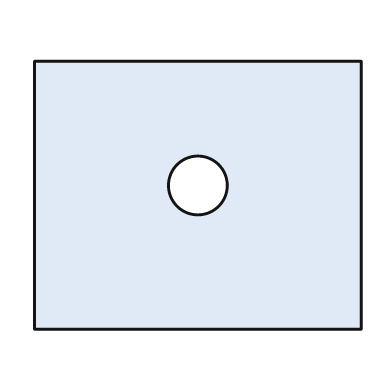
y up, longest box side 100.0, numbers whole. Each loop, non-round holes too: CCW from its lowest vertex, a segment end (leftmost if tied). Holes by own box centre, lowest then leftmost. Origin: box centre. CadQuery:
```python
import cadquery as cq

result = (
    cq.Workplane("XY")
    .moveTo(-50.0, -41.0)
    .lineTo(50.0, -41.0)
    .lineTo(50.0, 41.0)
    .lineTo(-50.0, 41.0)
    .close()
    .moveTo(0.0, 3.0)
    .circle(9.0)
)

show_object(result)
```